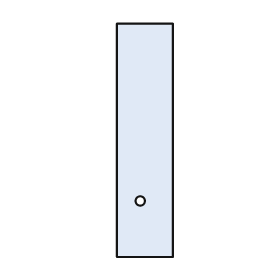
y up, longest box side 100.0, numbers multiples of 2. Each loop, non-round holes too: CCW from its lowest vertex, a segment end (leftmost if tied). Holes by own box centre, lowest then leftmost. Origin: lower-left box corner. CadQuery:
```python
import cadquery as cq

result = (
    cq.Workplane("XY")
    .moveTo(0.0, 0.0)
    .lineTo(24.0, 0.0)
    .lineTo(24.0, 100.0)
    .lineTo(0.0, 100.0)
    .close()
    .moveTo(10.0, 24.0)
    .circle(2.0)
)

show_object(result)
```